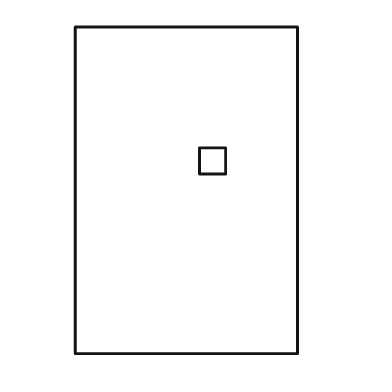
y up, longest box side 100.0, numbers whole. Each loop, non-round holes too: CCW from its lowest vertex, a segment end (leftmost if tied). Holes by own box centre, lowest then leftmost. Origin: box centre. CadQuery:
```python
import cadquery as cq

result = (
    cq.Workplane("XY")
    .moveTo(-34.0, -50.0)
    .lineTo(34.0, -50.0)
    .lineTo(34.0, 50.0)
    .lineTo(-34.0, 50.0)
    .close()
    .moveTo(4.0, 5.0)
    .lineTo(12.0, 5.0)
    .lineTo(12.0, 13.0)
    .lineTo(4.0, 13.0)
    .close()
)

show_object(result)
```